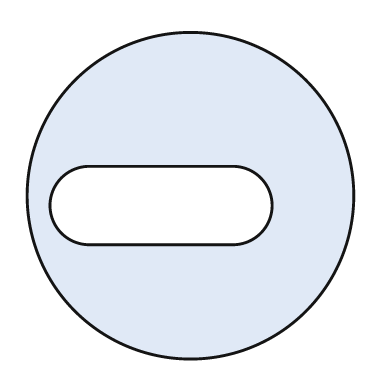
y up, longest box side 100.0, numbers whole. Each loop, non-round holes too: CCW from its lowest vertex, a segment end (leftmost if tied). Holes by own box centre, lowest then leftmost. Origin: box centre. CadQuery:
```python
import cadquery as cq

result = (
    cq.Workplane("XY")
    .moveTo(0.0, 0.0)
    .circle(50.0)
    .moveTo(-31.0, -15.0)
    .lineTo(13.0, -15.0)
    .threePointArc((25.0, -3.0), (13.0, 9.0))
    .lineTo(-31.0, 9.0)
    .threePointArc((-43.0, -3.0), (-31.0, -15.0))
    .close()
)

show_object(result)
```